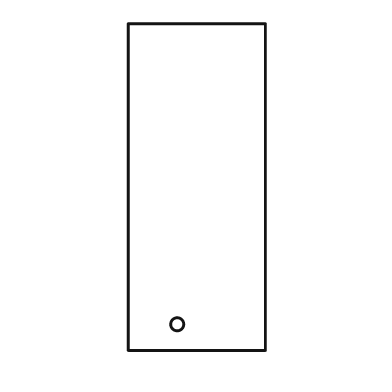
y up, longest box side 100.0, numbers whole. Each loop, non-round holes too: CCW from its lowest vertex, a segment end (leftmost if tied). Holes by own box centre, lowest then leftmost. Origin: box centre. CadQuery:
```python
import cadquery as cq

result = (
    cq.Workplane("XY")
    .moveTo(-21.0, -50.0)
    .lineTo(21.0, -50.0)
    .lineTo(21.0, 50.0)
    .lineTo(-21.0, 50.0)
    .close()
    .moveTo(-6.0, -42.0)
    .circle(2.0)
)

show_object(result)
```